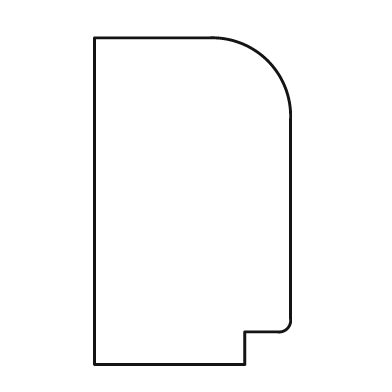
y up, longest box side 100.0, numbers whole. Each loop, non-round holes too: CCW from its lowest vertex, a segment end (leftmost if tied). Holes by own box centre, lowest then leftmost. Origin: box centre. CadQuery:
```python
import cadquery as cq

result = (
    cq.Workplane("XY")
    .moveTo(-30.0, -50.0)
    .lineTo(16.0, -50.0)
    .lineTo(16.0, -40.0)
    .lineTo(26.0, -40.0)
    .threePointArc((29.0, -39.0), (30.0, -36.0))
    .lineTo(30.0, 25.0)
    .threePointArc((23.0, 43.0), (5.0, 50.0))
    .lineTo(-30.0, 50.0)
    .close()
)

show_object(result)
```